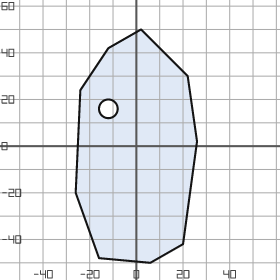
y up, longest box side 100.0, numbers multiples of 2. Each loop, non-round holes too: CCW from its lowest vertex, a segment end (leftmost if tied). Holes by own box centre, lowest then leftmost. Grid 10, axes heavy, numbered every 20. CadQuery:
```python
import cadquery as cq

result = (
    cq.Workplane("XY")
    .moveTo(6.0, -50.0)
    .lineTo(20.0, -42.0)
    .lineTo(26.0, 2.0)
    .lineTo(22.0, 30.0)
    .lineTo(2.0, 50.0)
    .lineTo(-12.0, 42.0)
    .lineTo(-24.0, 24.0)
    .lineTo(-26.0, -20.0)
    .lineTo(-16.0, -48.0)
    .close()
    .moveTo(-12.0, 16.0)
    .circle(4.0)
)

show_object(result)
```